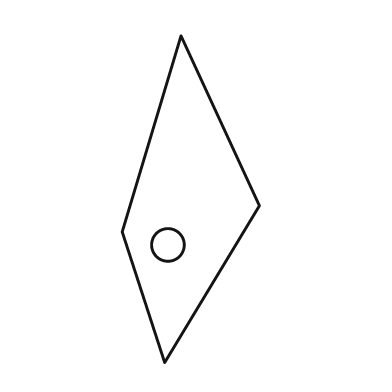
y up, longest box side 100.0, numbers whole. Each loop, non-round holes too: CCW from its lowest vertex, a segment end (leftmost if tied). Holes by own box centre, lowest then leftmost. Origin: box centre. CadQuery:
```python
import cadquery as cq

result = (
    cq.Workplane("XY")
    .moveTo(-8.0, -50.0)
    .lineTo(21.0, -2.0)
    .lineTo(-3.0, 50.0)
    .lineTo(-21.0, -10.0)
    .close()
    .moveTo(-7.0, -14.0)
    .circle(5.0)
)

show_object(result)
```